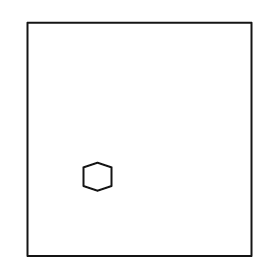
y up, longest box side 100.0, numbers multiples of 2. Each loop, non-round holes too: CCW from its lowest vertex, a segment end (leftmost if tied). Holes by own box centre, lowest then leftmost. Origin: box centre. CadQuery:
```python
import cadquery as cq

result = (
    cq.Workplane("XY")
    .moveTo(-48.0, -50.0)
    .lineTo(48.0, -50.0)
    .lineTo(48.0, 50.0)
    .lineTo(-48.0, 50.0)
    .close()
    .moveTo(-18.0, -22.0)
    .lineTo(-12.0, -20.0)
    .lineTo(-12.0, -12.0)
    .lineTo(-18.0, -10.0)
    .lineTo(-24.0, -12.0)
    .lineTo(-24.0, -20.0)
    .close()
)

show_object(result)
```